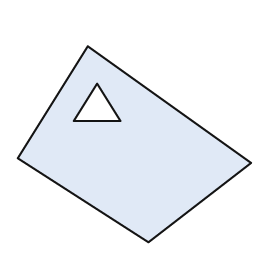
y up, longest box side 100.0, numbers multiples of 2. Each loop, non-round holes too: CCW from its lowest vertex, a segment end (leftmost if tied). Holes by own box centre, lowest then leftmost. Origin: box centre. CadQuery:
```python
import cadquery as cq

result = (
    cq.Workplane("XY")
    .moveTo(6.0, -42.0)
    .lineTo(50.0, -8.0)
    .lineTo(-20.0, 42.0)
    .lineTo(-50.0, -6.0)
    .close()
    .moveTo(-26.0, 10.0)
    .lineTo(-6.0, 10.0)
    .lineTo(-16.0, 26.0)
    .close()
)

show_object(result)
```